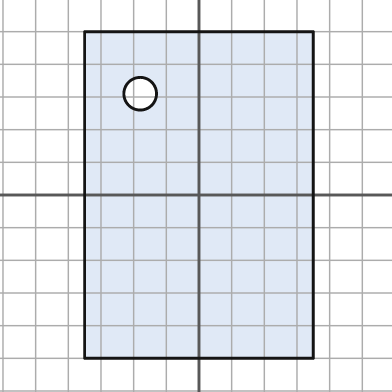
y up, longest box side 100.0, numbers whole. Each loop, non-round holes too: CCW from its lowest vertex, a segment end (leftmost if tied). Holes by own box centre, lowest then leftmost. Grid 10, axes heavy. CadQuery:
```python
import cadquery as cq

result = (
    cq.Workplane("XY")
    .moveTo(-35.0, -50.0)
    .lineTo(35.0, -50.0)
    .lineTo(35.0, 50.0)
    .lineTo(-35.0, 50.0)
    .close()
    .moveTo(-18.0, 31.0)
    .circle(5.0)
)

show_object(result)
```